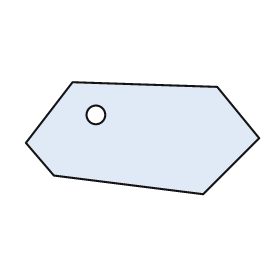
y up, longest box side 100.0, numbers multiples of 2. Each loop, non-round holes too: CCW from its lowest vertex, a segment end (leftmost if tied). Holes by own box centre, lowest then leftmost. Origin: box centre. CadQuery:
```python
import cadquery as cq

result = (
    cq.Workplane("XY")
    .moveTo(26.0, -24.0)
    .lineTo(50.0, 0.0)
    .lineTo(32.0, 22.0)
    .lineTo(-30.0, 24.0)
    .lineTo(-50.0, -2.0)
    .lineTo(-38.0, -16.0)
    .close()
    .moveTo(-20.0, 10.0)
    .circle(4.0)
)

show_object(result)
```